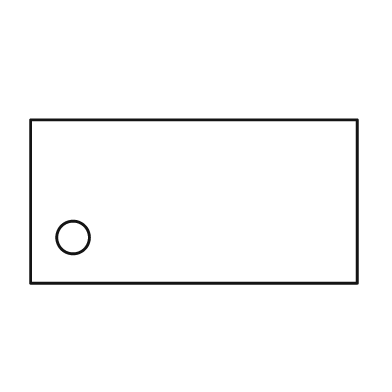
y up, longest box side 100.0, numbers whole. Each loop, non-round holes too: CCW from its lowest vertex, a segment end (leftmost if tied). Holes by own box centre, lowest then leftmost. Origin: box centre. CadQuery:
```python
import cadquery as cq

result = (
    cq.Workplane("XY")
    .moveTo(-50.0, -25.0)
    .lineTo(50.0, -25.0)
    .lineTo(50.0, 25.0)
    .lineTo(-50.0, 25.0)
    .close()
    .moveTo(-37.0, -11.0)
    .circle(5.0)
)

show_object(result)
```